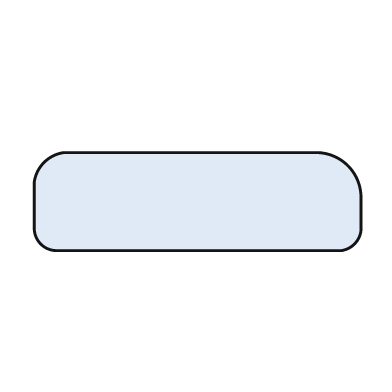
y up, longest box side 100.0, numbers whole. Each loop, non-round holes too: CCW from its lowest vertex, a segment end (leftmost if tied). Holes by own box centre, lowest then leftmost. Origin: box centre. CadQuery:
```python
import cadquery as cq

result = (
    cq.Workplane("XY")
    .moveTo(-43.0, -15.0)
    .lineTo(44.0, -15.0)
    .threePointArc((48.0, -13.0), (50.0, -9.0))
    .lineTo(50.0, 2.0)
    .threePointArc((46.0, 11.0), (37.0, 15.0))
    .lineTo(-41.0, 15.0)
    .threePointArc((-47.0, 12.0), (-50.0, 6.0))
    .lineTo(-50.0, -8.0)
    .threePointArc((-48.0, -13.0), (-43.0, -15.0))
    .close()
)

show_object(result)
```